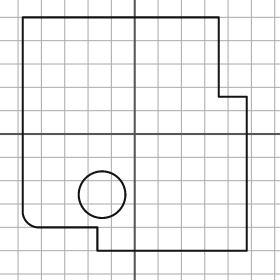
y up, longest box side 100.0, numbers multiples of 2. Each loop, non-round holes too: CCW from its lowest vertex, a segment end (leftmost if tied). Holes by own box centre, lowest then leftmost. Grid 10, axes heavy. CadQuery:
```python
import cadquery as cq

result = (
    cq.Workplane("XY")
    .moveTo(-16.0, -50.0)
    .lineTo(48.0, -50.0)
    .lineTo(48.0, 16.0)
    .lineTo(36.0, 16.0)
    .lineTo(36.0, 50.0)
    .lineTo(-48.0, 50.0)
    .lineTo(-48.0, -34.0)
    .threePointArc((-46.0, -38.0), (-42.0, -40.0))
    .lineTo(-16.0, -40.0)
    .close()
    .moveTo(-14.0, -26.0)
    .circle(10.0)
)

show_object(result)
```